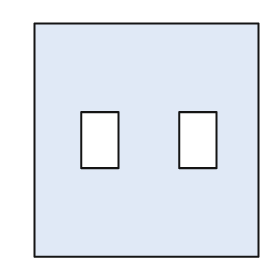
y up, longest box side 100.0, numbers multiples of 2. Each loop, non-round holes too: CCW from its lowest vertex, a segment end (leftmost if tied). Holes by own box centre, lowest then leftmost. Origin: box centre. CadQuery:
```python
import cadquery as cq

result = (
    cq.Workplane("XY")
    .moveTo(-48.0, -50.0)
    .lineTo(48.0, -50.0)
    .lineTo(48.0, 50.0)
    .lineTo(-48.0, 50.0)
    .close()
    .moveTo(-28.0, -12.0)
    .lineTo(-12.0, -12.0)
    .lineTo(-12.0, 12.0)
    .lineTo(-28.0, 12.0)
    .close()
    .moveTo(14.0, -12.0)
    .lineTo(30.0, -12.0)
    .lineTo(30.0, 12.0)
    .lineTo(14.0, 12.0)
    .close()
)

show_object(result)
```